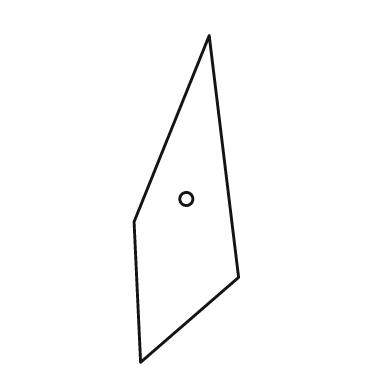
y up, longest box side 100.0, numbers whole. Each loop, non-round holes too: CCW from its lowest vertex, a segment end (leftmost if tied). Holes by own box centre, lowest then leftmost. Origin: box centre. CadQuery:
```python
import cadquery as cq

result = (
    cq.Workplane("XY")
    .moveTo(-14.0, -50.0)
    .lineTo(16.0, -24.0)
    .lineTo(7.0, 50.0)
    .lineTo(-16.0, -7.0)
    .close()
    .moveTo(0.0, 0.0)
    .circle(2.0)
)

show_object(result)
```